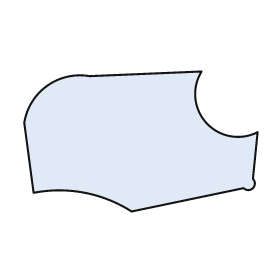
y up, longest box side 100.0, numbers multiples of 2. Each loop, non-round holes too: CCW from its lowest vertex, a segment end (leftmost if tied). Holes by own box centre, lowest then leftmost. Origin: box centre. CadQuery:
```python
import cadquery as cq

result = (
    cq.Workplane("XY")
    .moveTo(-4.0, -30.0)
    .lineTo(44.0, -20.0)
    .threePointArc((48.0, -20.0), (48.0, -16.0))
    .lineTo(50.0, 4.0)
    .threePointArc((28.0, 8.0), (26.0, 30.0))
    .lineTo(-22.0, 28.0)
    .threePointArc((-40.0, 24.0), (-50.0, 8.0))
    .lineTo(-46.0, -22.0)
    .threePointArc((-24.0, -22.0), (-4.0, -30.0))
    .close()
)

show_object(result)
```